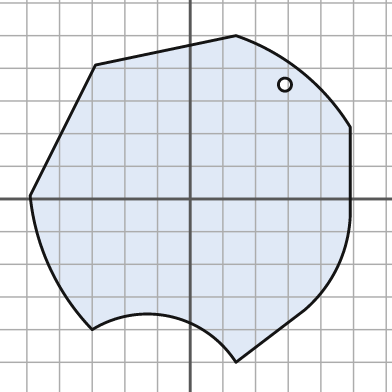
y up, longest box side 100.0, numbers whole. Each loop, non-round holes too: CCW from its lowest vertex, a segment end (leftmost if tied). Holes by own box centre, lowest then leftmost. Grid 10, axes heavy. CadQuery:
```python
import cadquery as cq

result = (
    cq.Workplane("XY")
    .moveTo(14.0, -50.0)
    .lineTo(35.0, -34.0)
    .threePointArc((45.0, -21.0), (49.0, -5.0))
    .lineTo(49.0, 22.0)
    .threePointArc((34.0, 39.0), (14.0, 50.0))
    .lineTo(-29.0, 41.0)
    .lineTo(-49.0, 1.0)
    .threePointArc((-43.0, -21.0), (-30.0, -40.0))
    .threePointArc((-6.0, -36.0), (14.0, -50.0))
    .close()
    .moveTo(29.0, 35.0)
    .circle(2.0)
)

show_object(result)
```